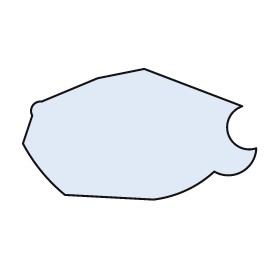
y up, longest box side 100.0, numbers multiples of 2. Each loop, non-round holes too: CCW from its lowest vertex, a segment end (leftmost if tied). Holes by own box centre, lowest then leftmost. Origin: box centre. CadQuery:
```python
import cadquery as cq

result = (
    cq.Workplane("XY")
    .moveTo(6.0, -28.0)
    .threePointArc((20.0, -24.0), (32.0, -16.0))
    .threePointArc((44.0, -16.0), (50.0, -6.0))
    .threePointArc((38.0, 0.0), (44.0, 12.0))
    .lineTo(2.0, 28.0)
    .lineTo(-18.0, 24.0)
    .lineTo(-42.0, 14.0)
    .threePointArc((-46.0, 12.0), (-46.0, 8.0))
    .lineTo(-50.0, -4.0)
    .threePointArc((-42.0, -16.0), (-32.0, -26.0))
    .close()
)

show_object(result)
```